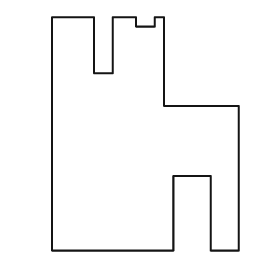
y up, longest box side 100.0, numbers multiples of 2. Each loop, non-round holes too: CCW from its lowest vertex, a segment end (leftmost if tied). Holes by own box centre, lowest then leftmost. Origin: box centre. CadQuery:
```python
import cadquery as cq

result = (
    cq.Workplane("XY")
    .moveTo(-40.0, -50.0)
    .lineTo(12.0, -50.0)
    .lineTo(12.0, -18.0)
    .lineTo(28.0, -18.0)
    .lineTo(28.0, -50.0)
    .lineTo(40.0, -50.0)
    .lineTo(40.0, 12.0)
    .lineTo(8.0, 12.0)
    .lineTo(8.0, 50.0)
    .lineTo(4.0, 50.0)
    .lineTo(4.0, 46.0)
    .lineTo(-4.0, 46.0)
    .lineTo(-4.0, 50.0)
    .lineTo(-14.0, 50.0)
    .lineTo(-14.0, 26.0)
    .lineTo(-22.0, 26.0)
    .lineTo(-22.0, 50.0)
    .lineTo(-40.0, 50.0)
    .close()
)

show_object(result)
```